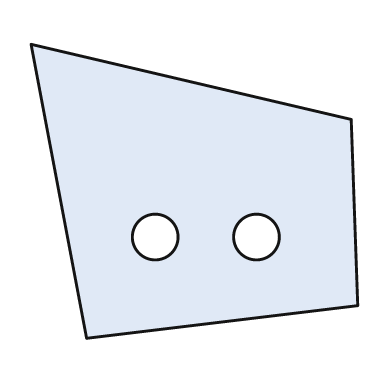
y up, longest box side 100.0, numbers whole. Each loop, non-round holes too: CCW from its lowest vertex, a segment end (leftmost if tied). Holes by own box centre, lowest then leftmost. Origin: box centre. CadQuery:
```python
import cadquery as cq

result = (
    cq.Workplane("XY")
    .moveTo(-33.0, -45.0)
    .lineTo(50.0, -35.0)
    .lineTo(48.0, 22.0)
    .lineTo(-50.0, 45.0)
    .close()
    .moveTo(-12.0, -14.0)
    .circle(7.0)
    .moveTo(19.0, -14.0)
    .circle(7.0)
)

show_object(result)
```